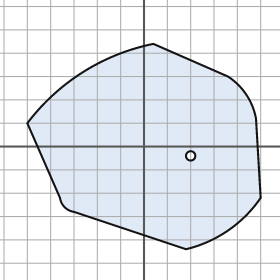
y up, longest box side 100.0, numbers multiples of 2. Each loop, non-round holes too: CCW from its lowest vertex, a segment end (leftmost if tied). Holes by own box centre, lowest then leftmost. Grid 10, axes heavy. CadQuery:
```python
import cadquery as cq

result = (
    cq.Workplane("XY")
    .moveTo(18.0, -44.0)
    .threePointArc((36.0, -36.0), (50.0, -22.0))
    .lineTo(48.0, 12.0)
    .threePointArc((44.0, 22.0), (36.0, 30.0))
    .lineTo(4.0, 44.0)
    .threePointArc((-26.0, 32.0), (-50.0, 10.0))
    .lineTo(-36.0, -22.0)
    .threePointArc((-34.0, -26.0), (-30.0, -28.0))
    .close()
    .moveTo(20.0, -4.0)
    .circle(2.0)
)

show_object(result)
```